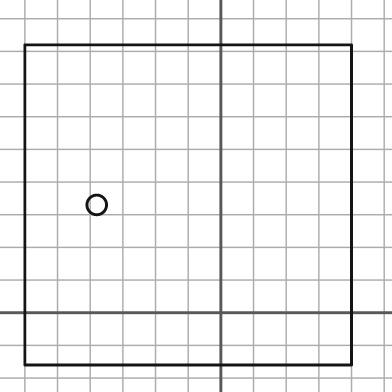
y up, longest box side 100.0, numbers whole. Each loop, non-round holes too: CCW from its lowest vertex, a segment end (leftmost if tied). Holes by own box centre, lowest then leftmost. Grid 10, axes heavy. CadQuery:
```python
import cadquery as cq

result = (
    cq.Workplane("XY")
    .moveTo(-60.0, -16.0)
    .lineTo(40.0, -16.0)
    .lineTo(40.0, 82.0)
    .lineTo(-60.0, 82.0)
    .close()
    .moveTo(-38.0, 33.0)
    .circle(3.0)
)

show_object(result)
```